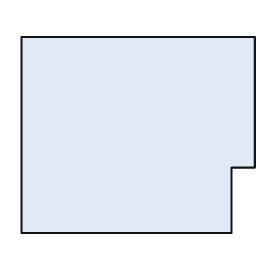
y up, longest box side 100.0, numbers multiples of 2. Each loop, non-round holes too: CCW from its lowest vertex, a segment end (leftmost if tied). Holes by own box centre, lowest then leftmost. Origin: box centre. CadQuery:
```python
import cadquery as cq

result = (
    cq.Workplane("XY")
    .moveTo(-50.0, -42.0)
    .lineTo(40.0, -42.0)
    .lineTo(40.0, -14.0)
    .lineTo(50.0, -14.0)
    .lineTo(50.0, 42.0)
    .lineTo(-50.0, 42.0)
    .close()
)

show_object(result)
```